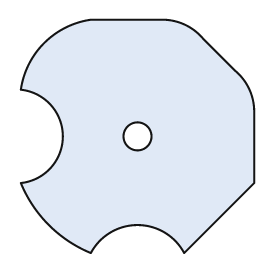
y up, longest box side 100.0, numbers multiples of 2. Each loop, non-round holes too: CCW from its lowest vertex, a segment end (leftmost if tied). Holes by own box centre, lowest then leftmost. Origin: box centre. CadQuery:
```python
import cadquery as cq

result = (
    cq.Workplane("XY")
    .moveTo(-20.0, -50.0)
    .threePointArc((0.0, -38.0), (20.0, -50.0))
    .lineTo(50.0, -20.0)
    .lineTo(50.0, 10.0)
    .threePointArc((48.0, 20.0), (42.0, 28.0))
    .lineTo(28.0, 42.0)
    .threePointArc((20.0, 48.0), (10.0, 50.0))
    .lineTo(-20.0, 50.0)
    .threePointArc((-40.0, 40.0), (-50.0, 20.0))
    .threePointArc((-32.0, 0.0), (-50.0, -20.0))
    .threePointArc((-38.0, -38.0), (-20.0, -50.0))
    .close()
    .moveTo(0.0, 0.0)
    .circle(6.0)
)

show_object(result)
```